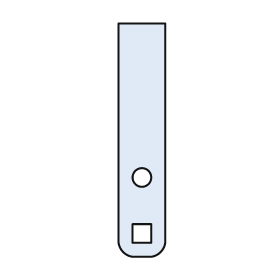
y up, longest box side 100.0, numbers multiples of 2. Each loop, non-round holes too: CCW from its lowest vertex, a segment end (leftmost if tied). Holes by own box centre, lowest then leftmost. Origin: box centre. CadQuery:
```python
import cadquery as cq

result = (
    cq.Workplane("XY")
    .moveTo(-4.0, -50.0)
    .lineTo(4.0, -50.0)
    .threePointArc((8.0, -48.0), (10.0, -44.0))
    .lineTo(10.0, 50.0)
    .lineTo(-10.0, 50.0)
    .lineTo(-10.0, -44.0)
    .threePointArc((-8.0, -48.0), (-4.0, -50.0))
    .close()
    .moveTo(-4.0, -44.0)
    .lineTo(4.0, -44.0)
    .lineTo(4.0, -36.0)
    .lineTo(-4.0, -36.0)
    .close()
    .moveTo(0.0, -16.0)
    .circle(4.0)
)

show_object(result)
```